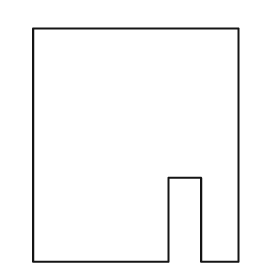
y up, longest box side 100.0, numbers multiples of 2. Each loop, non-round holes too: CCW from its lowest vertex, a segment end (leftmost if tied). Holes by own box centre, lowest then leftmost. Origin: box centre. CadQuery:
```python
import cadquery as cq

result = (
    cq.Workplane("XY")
    .moveTo(-44.0, -50.0)
    .lineTo(14.0, -50.0)
    .lineTo(14.0, -14.0)
    .lineTo(28.0, -14.0)
    .lineTo(28.0, -50.0)
    .lineTo(44.0, -50.0)
    .lineTo(44.0, 50.0)
    .lineTo(-44.0, 50.0)
    .close()
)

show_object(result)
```